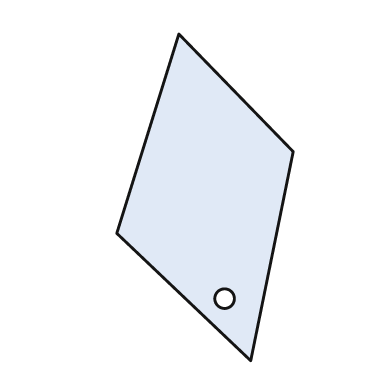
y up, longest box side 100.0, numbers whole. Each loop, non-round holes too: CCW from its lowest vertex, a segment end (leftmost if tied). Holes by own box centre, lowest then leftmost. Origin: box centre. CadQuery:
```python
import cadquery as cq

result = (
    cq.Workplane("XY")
    .moveTo(14.0, -50.0)
    .lineTo(27.0, 14.0)
    .lineTo(-8.0, 50.0)
    .lineTo(-27.0, -11.0)
    .close()
    .moveTo(6.0, -31.0)
    .circle(3.0)
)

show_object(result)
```